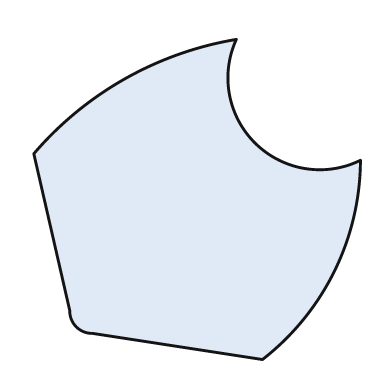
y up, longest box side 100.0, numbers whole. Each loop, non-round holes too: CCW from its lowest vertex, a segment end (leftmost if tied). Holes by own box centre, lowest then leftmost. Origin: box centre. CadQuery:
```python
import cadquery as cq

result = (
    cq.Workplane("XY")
    .moveTo(20.0, -49.0)
    .threePointArc((42.0, -22.0), (50.0, 12.0))
    .threePointArc((18.0, 17.0), (12.0, 49.0))
    .threePointArc((-22.0, 37.0), (-50.0, 14.0))
    .lineTo(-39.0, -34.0)
    .threePointArc((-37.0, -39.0), (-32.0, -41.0))
    .close()
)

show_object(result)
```